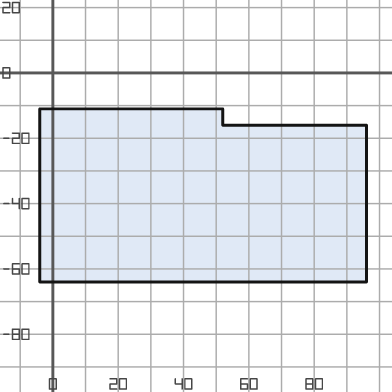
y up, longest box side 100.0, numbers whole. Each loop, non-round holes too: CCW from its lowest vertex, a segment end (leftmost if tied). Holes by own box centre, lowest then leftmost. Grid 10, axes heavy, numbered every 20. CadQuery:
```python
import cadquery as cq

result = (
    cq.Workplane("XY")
    .moveTo(-4.0, -64.0)
    .lineTo(96.0, -64.0)
    .lineTo(96.0, -16.0)
    .lineTo(52.0, -16.0)
    .lineTo(52.0, -11.0)
    .lineTo(-4.0, -11.0)
    .close()
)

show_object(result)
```